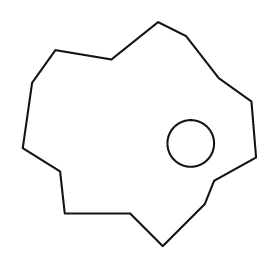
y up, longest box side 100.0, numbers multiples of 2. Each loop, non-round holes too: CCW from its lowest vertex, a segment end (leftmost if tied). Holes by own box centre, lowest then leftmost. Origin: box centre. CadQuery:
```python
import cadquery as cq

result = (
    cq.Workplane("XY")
    .moveTo(10.0, -48.0)
    .lineTo(28.0, -30.0)
    .lineTo(32.0, -20.0)
    .lineTo(50.0, -10.0)
    .lineTo(48.0, 14.0)
    .lineTo(34.0, 24.0)
    .lineTo(20.0, 42.0)
    .lineTo(8.0, 48.0)
    .lineTo(-12.0, 32.0)
    .lineTo(-36.0, 36.0)
    .lineTo(-46.0, 22.0)
    .lineTo(-50.0, -6.0)
    .lineTo(-34.0, -16.0)
    .lineTo(-32.0, -34.0)
    .lineTo(-4.0, -34.0)
    .close()
    .moveTo(22.0, -4.0)
    .circle(10.0)
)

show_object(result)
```